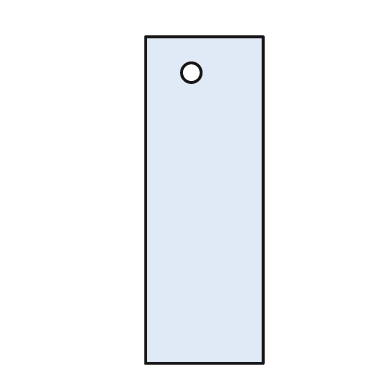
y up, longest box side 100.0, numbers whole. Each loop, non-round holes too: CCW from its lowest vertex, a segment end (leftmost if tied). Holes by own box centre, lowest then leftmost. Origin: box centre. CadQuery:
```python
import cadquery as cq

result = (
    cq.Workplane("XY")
    .moveTo(-18.0, -50.0)
    .lineTo(18.0, -50.0)
    .lineTo(18.0, 50.0)
    .lineTo(-18.0, 50.0)
    .close()
    .moveTo(-4.0, 39.0)
    .circle(3.0)
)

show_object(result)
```